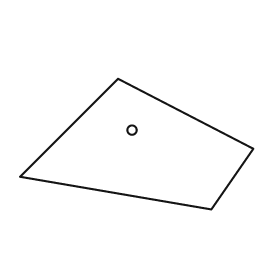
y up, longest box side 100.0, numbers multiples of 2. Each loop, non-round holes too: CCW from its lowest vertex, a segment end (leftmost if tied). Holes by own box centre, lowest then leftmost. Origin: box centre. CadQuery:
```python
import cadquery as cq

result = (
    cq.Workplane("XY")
    .moveTo(32.0, -28.0)
    .lineTo(50.0, -2.0)
    .lineTo(-8.0, 28.0)
    .lineTo(-50.0, -14.0)
    .close()
    .moveTo(-2.0, 6.0)
    .circle(2.0)
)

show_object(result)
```